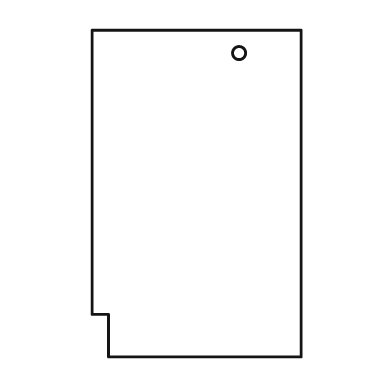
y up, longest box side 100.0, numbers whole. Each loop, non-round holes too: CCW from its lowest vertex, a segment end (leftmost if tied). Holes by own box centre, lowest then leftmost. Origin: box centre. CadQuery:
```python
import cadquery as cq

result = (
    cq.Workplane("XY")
    .moveTo(-27.0, -50.0)
    .lineTo(32.0, -50.0)
    .lineTo(32.0, 50.0)
    .lineTo(-32.0, 50.0)
    .lineTo(-32.0, -37.0)
    .lineTo(-27.0, -37.0)
    .close()
    .moveTo(13.0, 43.0)
    .circle(2.0)
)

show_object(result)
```